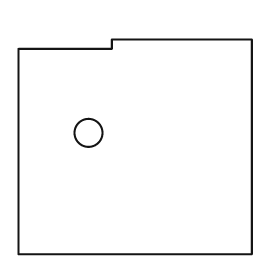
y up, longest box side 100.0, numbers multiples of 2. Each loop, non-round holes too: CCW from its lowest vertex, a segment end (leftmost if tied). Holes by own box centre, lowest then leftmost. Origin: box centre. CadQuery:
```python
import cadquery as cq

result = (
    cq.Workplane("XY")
    .moveTo(-50.0, -46.0)
    .lineTo(50.0, -46.0)
    .lineTo(50.0, 46.0)
    .lineTo(-10.0, 46.0)
    .lineTo(-10.0, 42.0)
    .lineTo(-50.0, 42.0)
    .close()
    .moveTo(-20.0, 6.0)
    .circle(6.0)
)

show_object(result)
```